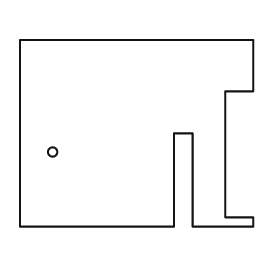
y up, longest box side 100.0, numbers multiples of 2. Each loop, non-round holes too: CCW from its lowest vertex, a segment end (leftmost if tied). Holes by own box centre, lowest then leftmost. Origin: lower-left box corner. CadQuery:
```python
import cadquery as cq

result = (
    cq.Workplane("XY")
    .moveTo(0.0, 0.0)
    .lineTo(66.0, 0.0)
    .lineTo(66.0, 40.0)
    .lineTo(74.0, 40.0)
    .lineTo(74.0, 0.0)
    .lineTo(100.0, 0.0)
    .lineTo(100.0, 4.0)
    .lineTo(88.0, 4.0)
    .lineTo(88.0, 58.0)
    .lineTo(100.0, 58.0)
    .lineTo(100.0, 80.0)
    .lineTo(0.0, 80.0)
    .close()
    .moveTo(14.0, 32.0)
    .circle(2.0)
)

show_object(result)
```